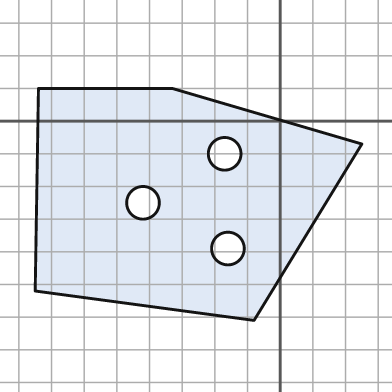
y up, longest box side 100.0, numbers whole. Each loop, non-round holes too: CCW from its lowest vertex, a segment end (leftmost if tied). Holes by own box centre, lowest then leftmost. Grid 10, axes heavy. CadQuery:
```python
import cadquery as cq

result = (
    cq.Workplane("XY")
    .moveTo(-8.0, -61.0)
    .lineTo(25.0, -7.0)
    .lineTo(-33.0, 10.0)
    .lineTo(-74.0, 10.0)
    .lineTo(-75.0, -52.0)
    .close()
    .moveTo(-16.0, -39.0)
    .circle(5.0)
    .moveTo(-42.0, -25.0)
    .circle(5.0)
    .moveTo(-17.0, -10.0)
    .circle(5.0)
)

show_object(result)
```